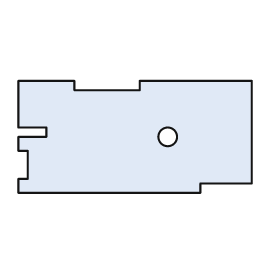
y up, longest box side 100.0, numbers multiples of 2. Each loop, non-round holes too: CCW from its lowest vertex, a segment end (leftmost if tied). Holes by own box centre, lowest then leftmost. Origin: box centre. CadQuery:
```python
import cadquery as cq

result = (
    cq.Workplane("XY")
    .moveTo(-50.0, -24.0)
    .lineTo(28.0, -24.0)
    .lineTo(28.0, -20.0)
    .lineTo(50.0, -20.0)
    .lineTo(50.0, 24.0)
    .lineTo(2.0, 24.0)
    .lineTo(2.0, 20.0)
    .lineTo(-26.0, 20.0)
    .lineTo(-26.0, 24.0)
    .lineTo(-50.0, 24.0)
    .lineTo(-50.0, 4.0)
    .lineTo(-38.0, 4.0)
    .lineTo(-38.0, 0.0)
    .lineTo(-50.0, 0.0)
    .lineTo(-50.0, -6.0)
    .lineTo(-46.0, -6.0)
    .lineTo(-46.0, -18.0)
    .lineTo(-50.0, -18.0)
    .close()
    .moveTo(14.0, 0.0)
    .circle(4.0)
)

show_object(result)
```